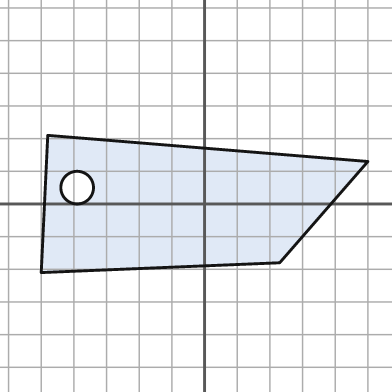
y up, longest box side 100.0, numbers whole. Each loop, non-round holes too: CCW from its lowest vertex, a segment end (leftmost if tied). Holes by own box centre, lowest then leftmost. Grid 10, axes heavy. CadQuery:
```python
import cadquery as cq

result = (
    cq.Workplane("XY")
    .moveTo(-50.0, -21.0)
    .lineTo(23.0, -18.0)
    .lineTo(50.0, 13.0)
    .lineTo(-48.0, 21.0)
    .close()
    .moveTo(-39.0, 5.0)
    .circle(5.0)
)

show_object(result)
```